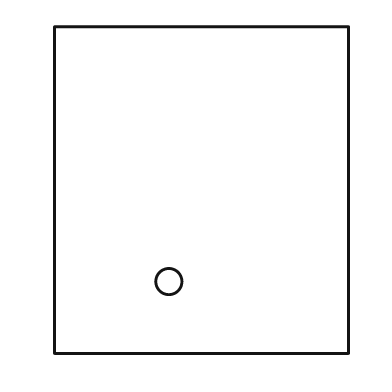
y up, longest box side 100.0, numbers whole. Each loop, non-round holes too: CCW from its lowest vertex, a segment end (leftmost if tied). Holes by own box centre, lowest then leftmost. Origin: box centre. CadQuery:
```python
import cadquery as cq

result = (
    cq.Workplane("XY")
    .moveTo(-45.0, -50.0)
    .lineTo(45.0, -50.0)
    .lineTo(45.0, 50.0)
    .lineTo(-45.0, 50.0)
    .close()
    .moveTo(-10.0, -28.0)
    .circle(4.0)
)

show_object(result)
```